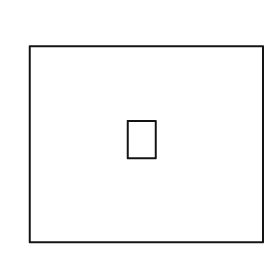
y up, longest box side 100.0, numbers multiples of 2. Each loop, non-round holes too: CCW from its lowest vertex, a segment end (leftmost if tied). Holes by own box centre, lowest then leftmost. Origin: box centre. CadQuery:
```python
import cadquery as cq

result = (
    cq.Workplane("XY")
    .moveTo(-50.0, -42.0)
    .lineTo(50.0, -42.0)
    .lineTo(50.0, 42.0)
    .lineTo(-50.0, 42.0)
    .close()
    .moveTo(-8.0, -6.0)
    .lineTo(4.0, -6.0)
    .lineTo(4.0, 10.0)
    .lineTo(-8.0, 10.0)
    .close()
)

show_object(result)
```